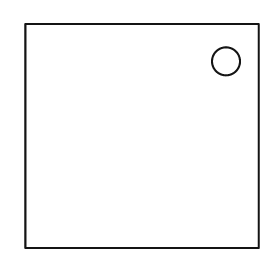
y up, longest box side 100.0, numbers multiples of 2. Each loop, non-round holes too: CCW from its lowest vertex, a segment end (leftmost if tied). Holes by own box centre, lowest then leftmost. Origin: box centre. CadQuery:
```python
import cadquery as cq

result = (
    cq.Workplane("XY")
    .moveTo(-50.0, -48.0)
    .lineTo(50.0, -48.0)
    .lineTo(50.0, 48.0)
    .lineTo(-50.0, 48.0)
    .close()
    .moveTo(36.0, 32.0)
    .circle(6.0)
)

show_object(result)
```